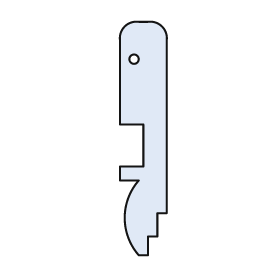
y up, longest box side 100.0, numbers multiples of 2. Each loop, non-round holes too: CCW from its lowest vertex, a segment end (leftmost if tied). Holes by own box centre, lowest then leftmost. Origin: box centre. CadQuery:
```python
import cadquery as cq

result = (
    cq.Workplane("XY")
    .moveTo(-2.0, -50.0)
    .lineTo(2.0, -50.0)
    .lineTo(2.0, -42.0)
    .lineTo(6.0, -42.0)
    .lineTo(6.0, -32.0)
    .lineTo(10.0, -32.0)
    .lineTo(10.0, 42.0)
    .threePointArc((8.0, 48.0), (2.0, 50.0))
    .lineTo(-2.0, 50.0)
    .threePointArc((-8.0, 48.0), (-10.0, 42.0))
    .lineTo(-10.0, 6.0)
    .lineTo(0.0, 6.0)
    .lineTo(0.0, -12.0)
    .lineTo(-10.0, -12.0)
    .lineTo(-10.0, -18.0)
    .lineTo(-2.0, -18.0)
    .threePointArc((-8.0, -34.0), (-2.0, -50.0))
    .close()
    .moveTo(-4.0, 34.0)
    .circle(2.0)
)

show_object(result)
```